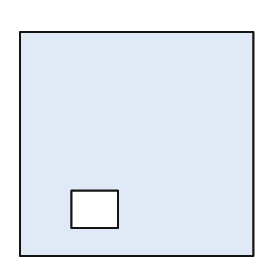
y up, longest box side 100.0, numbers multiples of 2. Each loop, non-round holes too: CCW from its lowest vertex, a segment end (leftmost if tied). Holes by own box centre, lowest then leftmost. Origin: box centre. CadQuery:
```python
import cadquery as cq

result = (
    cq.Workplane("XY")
    .moveTo(-50.0, -48.0)
    .lineTo(50.0, -48.0)
    .lineTo(50.0, 48.0)
    .lineTo(-50.0, 48.0)
    .close()
    .moveTo(-28.0, -36.0)
    .lineTo(-8.0, -36.0)
    .lineTo(-8.0, -20.0)
    .lineTo(-28.0, -20.0)
    .close()
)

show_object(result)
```